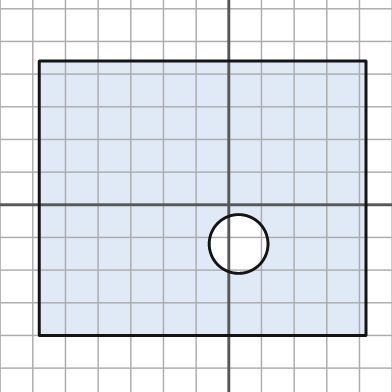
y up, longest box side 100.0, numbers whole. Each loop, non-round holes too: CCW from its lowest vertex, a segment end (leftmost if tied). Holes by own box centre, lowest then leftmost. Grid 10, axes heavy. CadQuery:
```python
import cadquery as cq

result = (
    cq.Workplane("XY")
    .moveTo(-58.0, -40.0)
    .lineTo(42.0, -40.0)
    .lineTo(42.0, 44.0)
    .lineTo(-58.0, 44.0)
    .close()
    .moveTo(3.0, -12.0)
    .circle(9.0)
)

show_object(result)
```